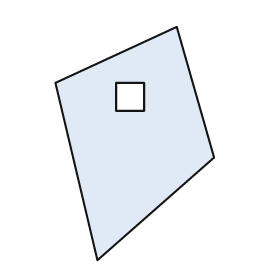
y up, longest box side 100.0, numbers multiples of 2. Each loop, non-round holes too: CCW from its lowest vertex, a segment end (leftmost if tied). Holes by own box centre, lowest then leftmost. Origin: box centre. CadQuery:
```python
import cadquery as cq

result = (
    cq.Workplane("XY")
    .moveTo(-16.0, -50.0)
    .lineTo(34.0, -6.0)
    .lineTo(18.0, 50.0)
    .lineTo(-34.0, 26.0)
    .close()
    .moveTo(-8.0, 14.0)
    .lineTo(4.0, 14.0)
    .lineTo(4.0, 26.0)
    .lineTo(-8.0, 26.0)
    .close()
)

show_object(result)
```